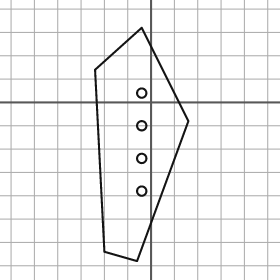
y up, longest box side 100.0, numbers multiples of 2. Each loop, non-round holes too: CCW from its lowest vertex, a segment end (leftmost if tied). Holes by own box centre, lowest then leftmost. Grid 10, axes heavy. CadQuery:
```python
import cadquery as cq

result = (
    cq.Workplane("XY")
    .moveTo(-6.0, -68.0)
    .lineTo(16.0, -8.0)
    .lineTo(-4.0, 32.0)
    .lineTo(-24.0, 14.0)
    .lineTo(-20.0, -64.0)
    .close()
    .moveTo(-4.0, -38.0)
    .circle(2.0)
    .moveTo(-4.0, -24.0)
    .circle(2.0)
    .moveTo(-4.0, -10.0)
    .circle(2.0)
    .moveTo(-4.0, 4.0)
    .circle(2.0)
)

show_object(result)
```